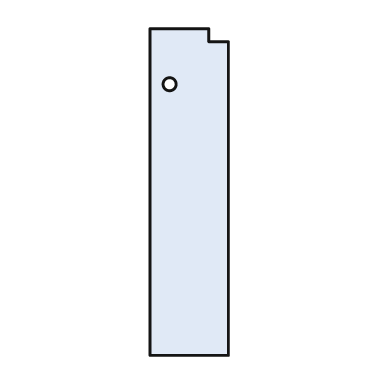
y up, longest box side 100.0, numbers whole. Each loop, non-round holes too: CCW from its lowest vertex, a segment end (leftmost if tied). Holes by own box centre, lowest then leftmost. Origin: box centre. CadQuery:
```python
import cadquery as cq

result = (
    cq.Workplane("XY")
    .moveTo(-12.0, -50.0)
    .lineTo(12.0, -50.0)
    .lineTo(12.0, 46.0)
    .lineTo(6.0, 46.0)
    .lineTo(6.0, 50.0)
    .lineTo(-12.0, 50.0)
    .close()
    .moveTo(-6.0, 33.0)
    .circle(2.0)
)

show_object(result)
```